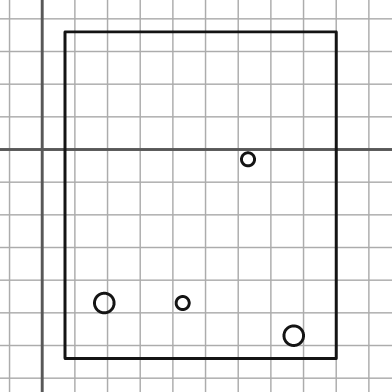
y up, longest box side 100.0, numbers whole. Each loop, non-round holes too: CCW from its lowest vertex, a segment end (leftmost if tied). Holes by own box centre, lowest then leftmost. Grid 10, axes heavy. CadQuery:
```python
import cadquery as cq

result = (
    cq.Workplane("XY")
    .moveTo(7.0, -64.0)
    .lineTo(90.0, -64.0)
    .lineTo(90.0, 36.0)
    .lineTo(7.0, 36.0)
    .close()
    .moveTo(77.0, -57.0)
    .circle(3.0)
    .moveTo(19.0, -47.0)
    .circle(3.0)
    .moveTo(43.0, -47.0)
    .circle(2.0)
    .moveTo(63.0, -3.0)
    .circle(2.0)
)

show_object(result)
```